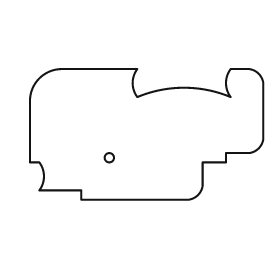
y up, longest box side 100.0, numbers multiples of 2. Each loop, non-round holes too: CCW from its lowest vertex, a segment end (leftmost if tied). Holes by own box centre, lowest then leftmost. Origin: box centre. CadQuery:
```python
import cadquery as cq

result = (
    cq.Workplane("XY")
    .moveTo(-28.0, -28.0)
    .lineTo(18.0, -28.0)
    .threePointArc((22.0, -26.0), (24.0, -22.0))
    .lineTo(24.0, -12.0)
    .lineTo(34.0, -12.0)
    .lineTo(34.0, -8.0)
    .lineTo(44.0, -8.0)
    .threePointArc((48.0, -6.0), (50.0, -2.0))
    .lineTo(50.0, 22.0)
    .threePointArc((48.0, 26.0), (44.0, 28.0))
    .lineTo(36.0, 28.0)
    .threePointArc((34.0, 22.0), (36.0, 16.0))
    .threePointArc((16.0, 20.0), (-4.0, 16.0))
    .threePointArc((-6.0, 22.0), (-4.0, 28.0))
    .lineTo(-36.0, 28.0)
    .threePointArc((-46.0, 24.0), (-50.0, 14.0))
    .lineTo(-50.0, -12.0)
    .lineTo(-46.0, -12.0)
    .threePointArc((-44.0, -18.0), (-46.0, -24.0))
    .lineTo(-28.0, -24.0)
    .close()
    .moveTo(-16.0, -10.0)
    .circle(2.0)
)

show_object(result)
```